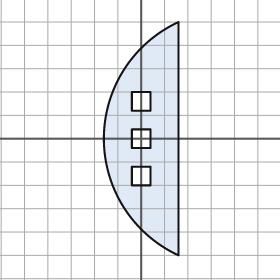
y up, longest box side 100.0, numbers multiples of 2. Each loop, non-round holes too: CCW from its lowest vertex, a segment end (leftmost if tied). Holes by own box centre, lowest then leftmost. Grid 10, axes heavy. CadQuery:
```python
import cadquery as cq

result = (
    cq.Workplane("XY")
    .moveTo(16.0, -50.0)
    .lineTo(16.0, 50.0)
    .threePointArc((-16.0, 0.0), (16.0, -50.0))
    .close()
    .moveTo(-4.0, -20.0)
    .lineTo(4.0, -20.0)
    .lineTo(4.0, -12.0)
    .lineTo(-4.0, -12.0)
    .close()
    .moveTo(-4.0, -4.0)
    .lineTo(4.0, -4.0)
    .lineTo(4.0, 4.0)
    .lineTo(-4.0, 4.0)
    .close()
    .moveTo(-4.0, 12.0)
    .lineTo(4.0, 12.0)
    .lineTo(4.0, 20.0)
    .lineTo(-4.0, 20.0)
    .close()
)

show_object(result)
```